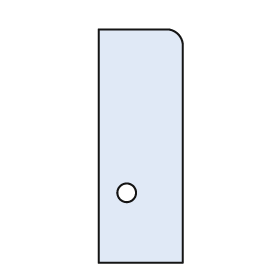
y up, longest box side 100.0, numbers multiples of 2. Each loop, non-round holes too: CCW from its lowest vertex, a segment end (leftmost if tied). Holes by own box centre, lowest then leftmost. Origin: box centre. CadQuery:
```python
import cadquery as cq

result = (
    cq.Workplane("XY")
    .moveTo(-18.0, -50.0)
    .lineTo(18.0, -50.0)
    .lineTo(18.0, 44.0)
    .threePointArc((16.0, 48.0), (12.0, 50.0))
    .lineTo(-18.0, 50.0)
    .close()
    .moveTo(-6.0, -20.0)
    .circle(4.0)
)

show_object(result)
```